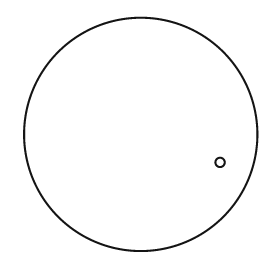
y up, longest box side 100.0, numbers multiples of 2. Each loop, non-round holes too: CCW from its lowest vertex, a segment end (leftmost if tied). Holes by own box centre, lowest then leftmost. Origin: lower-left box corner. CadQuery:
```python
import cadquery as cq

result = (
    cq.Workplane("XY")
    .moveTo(50.0, 50.0)
    .circle(50.0)
    .moveTo(84.0, 38.0)
    .circle(2.0)
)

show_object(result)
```